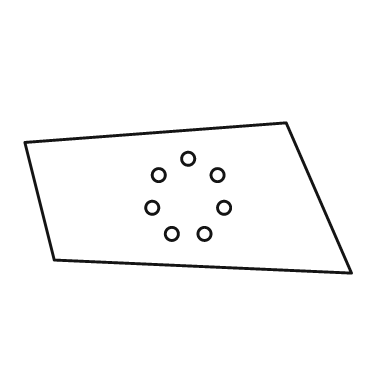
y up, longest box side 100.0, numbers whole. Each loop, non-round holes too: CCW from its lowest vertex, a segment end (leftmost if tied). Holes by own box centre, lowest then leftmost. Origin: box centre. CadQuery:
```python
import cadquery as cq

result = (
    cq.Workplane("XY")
    .moveTo(50.0, -23.0)
    .lineTo(30.0, 23.0)
    .lineTo(-50.0, 17.0)
    .lineTo(-41.0, -19.0)
    .close()
    .moveTo(-5.0, -11.0)
    .circle(2.0)
    .moveTo(5.0, -11.0)
    .circle(2.0)
    .moveTo(-11.0, -3.0)
    .circle(2.0)
    .moveTo(11.0, -3.0)
    .circle(2.0)
    .moveTo(-9.0, 7.0)
    .circle(2.0)
    .moveTo(9.0, 7.0)
    .circle(2.0)
    .moveTo(0.0, 12.0)
    .circle(2.0)
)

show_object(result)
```